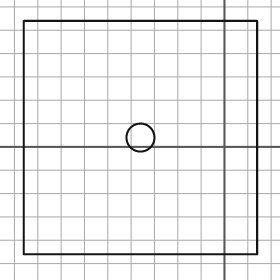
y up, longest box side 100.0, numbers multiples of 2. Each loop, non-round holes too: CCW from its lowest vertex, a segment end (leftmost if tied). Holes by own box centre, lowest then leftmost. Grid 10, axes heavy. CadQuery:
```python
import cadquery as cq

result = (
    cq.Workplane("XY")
    .moveTo(-86.0, -46.0)
    .lineTo(14.0, -46.0)
    .lineTo(14.0, 54.0)
    .lineTo(-86.0, 54.0)
    .close()
    .moveTo(-36.0, 4.0)
    .circle(6.0)
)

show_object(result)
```